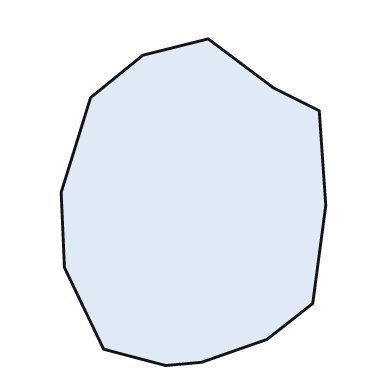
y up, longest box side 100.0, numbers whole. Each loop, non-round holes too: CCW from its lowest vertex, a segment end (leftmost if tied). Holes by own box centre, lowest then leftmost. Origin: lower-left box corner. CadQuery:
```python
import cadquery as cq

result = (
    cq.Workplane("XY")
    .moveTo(32.0, 0.0)
    .lineTo(43.0, 1.0)
    .lineTo(63.0, 8.0)
    .lineTo(77.0, 19.0)
    .lineTo(81.0, 49.0)
    .lineTo(79.0, 78.0)
    .lineTo(65.0, 85.0)
    .lineTo(45.0, 100.0)
    .lineTo(25.0, 95.0)
    .lineTo(9.0, 82.0)
    .lineTo(0.0, 53.0)
    .lineTo(1.0, 30.0)
    .lineTo(13.0, 5.0)
    .close()
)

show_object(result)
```